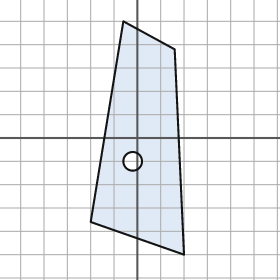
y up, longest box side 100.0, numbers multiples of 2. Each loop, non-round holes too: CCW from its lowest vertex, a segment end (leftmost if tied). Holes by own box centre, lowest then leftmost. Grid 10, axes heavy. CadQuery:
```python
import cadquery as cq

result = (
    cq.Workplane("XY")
    .moveTo(20.0, -50.0)
    .lineTo(16.0, 38.0)
    .lineTo(-6.0, 50.0)
    .lineTo(-20.0, -36.0)
    .close()
    .moveTo(-2.0, -10.0)
    .circle(4.0)
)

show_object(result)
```